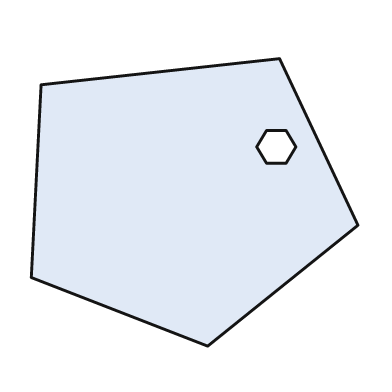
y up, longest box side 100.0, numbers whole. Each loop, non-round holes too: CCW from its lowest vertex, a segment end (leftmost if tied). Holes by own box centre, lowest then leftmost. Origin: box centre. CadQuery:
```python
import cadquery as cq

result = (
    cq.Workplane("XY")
    .moveTo(4.0, -44.0)
    .lineTo(50.0, -7.0)
    .lineTo(26.0, 44.0)
    .lineTo(-47.0, 36.0)
    .lineTo(-50.0, -23.0)
    .close()
    .moveTo(22.0, 12.0)
    .lineTo(28.0, 12.0)
    .lineTo(31.0, 17.0)
    .lineTo(28.0, 22.0)
    .lineTo(22.0, 22.0)
    .lineTo(19.0, 17.0)
    .close()
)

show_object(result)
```